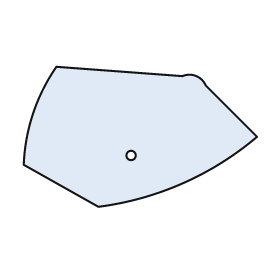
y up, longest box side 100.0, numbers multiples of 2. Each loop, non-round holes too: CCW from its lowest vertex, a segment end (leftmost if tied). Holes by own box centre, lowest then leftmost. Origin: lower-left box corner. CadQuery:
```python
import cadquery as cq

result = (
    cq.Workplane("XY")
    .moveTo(32.0, 0.0)
    .threePointArc((68.0, 10.0), (100.0, 30.0))
    .lineTo(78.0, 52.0)
    .threePointArc((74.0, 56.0), (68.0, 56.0))
    .lineTo(14.0, 60.0)
    .threePointArc((4.0, 40.0), (0.0, 18.0))
    .close()
    .moveTo(46.0, 22.0)
    .circle(2.0)
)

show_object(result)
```